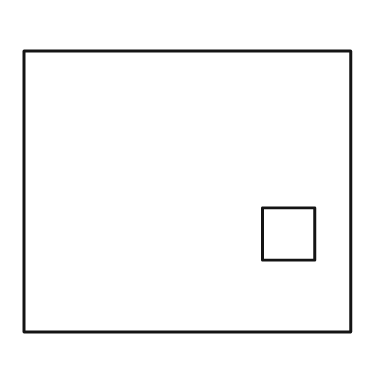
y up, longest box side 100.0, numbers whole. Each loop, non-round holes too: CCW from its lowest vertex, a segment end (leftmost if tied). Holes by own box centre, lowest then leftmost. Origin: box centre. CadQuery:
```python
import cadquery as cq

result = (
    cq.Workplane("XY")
    .moveTo(-50.0, -43.0)
    .lineTo(50.0, -43.0)
    .lineTo(50.0, 43.0)
    .lineTo(-50.0, 43.0)
    .close()
    .moveTo(23.0, -21.0)
    .lineTo(39.0, -21.0)
    .lineTo(39.0, -5.0)
    .lineTo(23.0, -5.0)
    .close()
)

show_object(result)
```